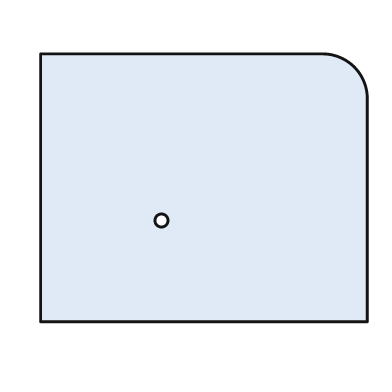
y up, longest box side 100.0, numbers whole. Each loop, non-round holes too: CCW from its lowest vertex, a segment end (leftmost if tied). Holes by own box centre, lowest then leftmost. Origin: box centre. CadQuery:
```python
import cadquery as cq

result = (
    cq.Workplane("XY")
    .moveTo(-50.0, -41.0)
    .lineTo(50.0, -41.0)
    .lineTo(50.0, 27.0)
    .threePointArc((46.0, 37.0), (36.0, 41.0))
    .lineTo(-50.0, 41.0)
    .close()
    .moveTo(-13.0, -10.0)
    .circle(2.0)
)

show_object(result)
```